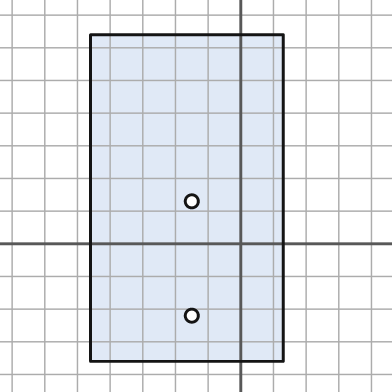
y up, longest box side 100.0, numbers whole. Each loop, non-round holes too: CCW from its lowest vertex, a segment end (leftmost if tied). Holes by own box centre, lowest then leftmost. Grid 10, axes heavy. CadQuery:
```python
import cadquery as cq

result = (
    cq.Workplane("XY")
    .moveTo(-46.0, -36.0)
    .lineTo(13.0, -36.0)
    .lineTo(13.0, 64.0)
    .lineTo(-46.0, 64.0)
    .close()
    .moveTo(-15.0, -22.0)
    .circle(2.0)
    .moveTo(-15.0, 13.0)
    .circle(2.0)
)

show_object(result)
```